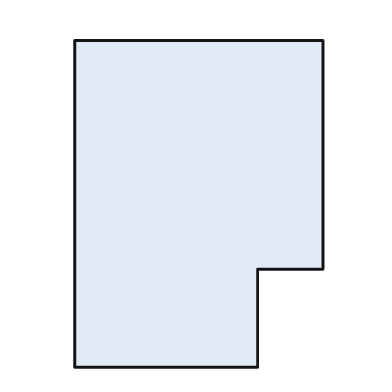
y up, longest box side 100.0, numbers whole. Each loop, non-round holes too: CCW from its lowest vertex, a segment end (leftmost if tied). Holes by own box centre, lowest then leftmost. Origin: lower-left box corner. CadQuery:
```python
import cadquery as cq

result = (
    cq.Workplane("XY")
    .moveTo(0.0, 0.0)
    .lineTo(56.0, 0.0)
    .lineTo(56.0, 30.0)
    .lineTo(76.0, 30.0)
    .lineTo(76.0, 100.0)
    .lineTo(0.0, 100.0)
    .close()
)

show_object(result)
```